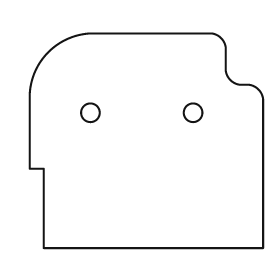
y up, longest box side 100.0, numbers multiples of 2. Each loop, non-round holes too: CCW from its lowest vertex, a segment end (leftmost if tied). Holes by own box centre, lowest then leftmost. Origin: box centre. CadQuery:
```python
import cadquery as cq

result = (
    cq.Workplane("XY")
    .moveTo(-44.0, -46.0)
    .lineTo(50.0, -46.0)
    .lineTo(50.0, 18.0)
    .threePointArc((48.0, 22.0), (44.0, 24.0))
    .lineTo(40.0, 24.0)
    .threePointArc((36.0, 26.0), (34.0, 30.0))
    .lineTo(34.0, 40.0)
    .threePointArc((32.0, 44.0), (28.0, 46.0))
    .lineTo(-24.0, 46.0)
    .threePointArc((-42.0, 38.0), (-50.0, 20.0))
    .lineTo(-50.0, -12.0)
    .lineTo(-44.0, -12.0)
    .close()
    .moveTo(-24.0, 12.0)
    .circle(4.0)
    .moveTo(20.0, 12.0)
    .circle(4.0)
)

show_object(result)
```